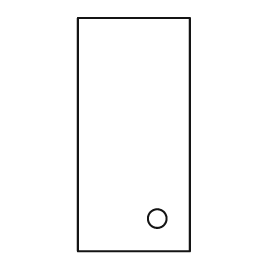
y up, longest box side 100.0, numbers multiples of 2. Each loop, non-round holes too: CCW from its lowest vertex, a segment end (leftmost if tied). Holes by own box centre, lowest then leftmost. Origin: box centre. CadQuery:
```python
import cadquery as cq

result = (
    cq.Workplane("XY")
    .moveTo(-24.0, -50.0)
    .lineTo(24.0, -50.0)
    .lineTo(24.0, 50.0)
    .lineTo(-24.0, 50.0)
    .close()
    .moveTo(10.0, -36.0)
    .circle(4.0)
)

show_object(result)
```